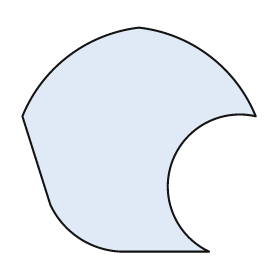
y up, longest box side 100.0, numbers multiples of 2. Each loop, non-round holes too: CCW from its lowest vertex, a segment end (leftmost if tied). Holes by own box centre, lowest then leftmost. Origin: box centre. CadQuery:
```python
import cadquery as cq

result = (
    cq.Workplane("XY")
    .moveTo(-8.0, -48.0)
    .lineTo(30.0, -48.0)
    .threePointArc((14.0, -10.0), (50.0, 10.0))
    .threePointArc((30.0, 36.0), (0.0, 48.0))
    .threePointArc((-30.0, 36.0), (-50.0, 10.0))
    .lineTo(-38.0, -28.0)
    .threePointArc((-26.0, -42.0), (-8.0, -48.0))
    .close()
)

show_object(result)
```